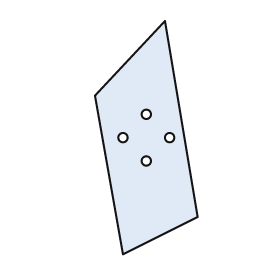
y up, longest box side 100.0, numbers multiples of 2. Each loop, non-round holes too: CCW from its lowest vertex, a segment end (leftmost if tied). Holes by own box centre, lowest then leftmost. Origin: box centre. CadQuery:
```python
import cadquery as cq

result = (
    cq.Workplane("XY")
    .moveTo(-10.0, -50.0)
    .lineTo(22.0, -34.0)
    .lineTo(8.0, 50.0)
    .lineTo(-22.0, 18.0)
    .close()
    .moveTo(0.0, -10.0)
    .circle(2.0)
    .moveTo(-10.0, 0.0)
    .circle(2.0)
    .moveTo(10.0, 0.0)
    .circle(2.0)
    .moveTo(0.0, 10.0)
    .circle(2.0)
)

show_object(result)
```